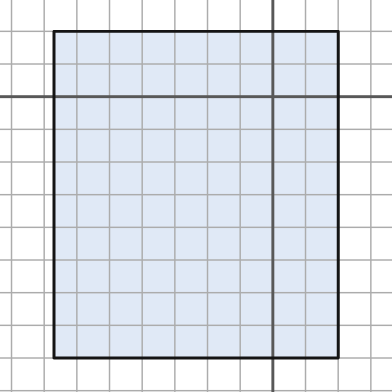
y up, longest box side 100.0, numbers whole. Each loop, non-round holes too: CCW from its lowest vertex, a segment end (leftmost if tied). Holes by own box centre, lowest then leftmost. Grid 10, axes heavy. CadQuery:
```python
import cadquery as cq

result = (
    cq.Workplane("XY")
    .moveTo(-67.0, -80.0)
    .lineTo(20.0, -80.0)
    .lineTo(20.0, 20.0)
    .lineTo(-67.0, 20.0)
    .close()
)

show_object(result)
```